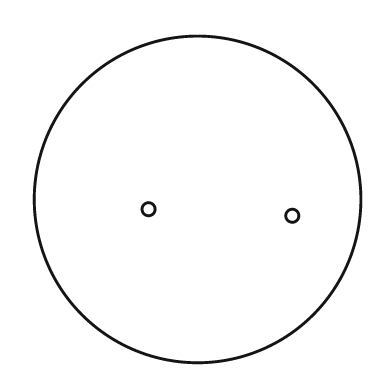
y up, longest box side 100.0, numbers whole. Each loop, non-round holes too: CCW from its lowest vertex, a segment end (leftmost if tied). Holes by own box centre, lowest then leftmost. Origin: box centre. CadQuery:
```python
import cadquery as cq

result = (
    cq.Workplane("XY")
    .moveTo(0.0, 0.0)
    .circle(50.0)
    .moveTo(29.0, -5.0)
    .circle(2.0)
    .moveTo(-15.0, -3.0)
    .circle(2.0)
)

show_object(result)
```